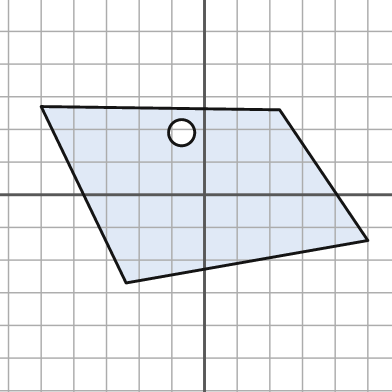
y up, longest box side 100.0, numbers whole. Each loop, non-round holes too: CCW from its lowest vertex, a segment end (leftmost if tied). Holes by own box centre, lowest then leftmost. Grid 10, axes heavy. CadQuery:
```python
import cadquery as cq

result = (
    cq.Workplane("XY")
    .moveTo(-24.0, -27.0)
    .lineTo(50.0, -14.0)
    .lineTo(23.0, 26.0)
    .lineTo(-50.0, 27.0)
    .close()
    .moveTo(-7.0, 19.0)
    .circle(4.0)
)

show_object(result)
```